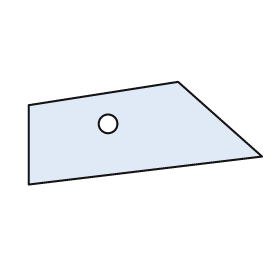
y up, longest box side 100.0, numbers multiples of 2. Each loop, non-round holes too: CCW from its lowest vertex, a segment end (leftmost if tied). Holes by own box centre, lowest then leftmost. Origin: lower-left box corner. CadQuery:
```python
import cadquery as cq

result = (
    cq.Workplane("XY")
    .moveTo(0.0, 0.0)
    .lineTo(100.0, 12.0)
    .lineTo(64.0, 44.0)
    .lineTo(0.0, 34.0)
    .close()
    .moveTo(34.0, 26.0)
    .circle(4.0)
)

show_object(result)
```